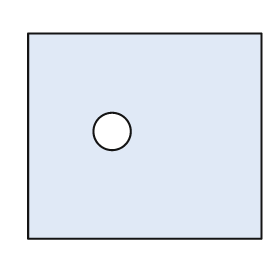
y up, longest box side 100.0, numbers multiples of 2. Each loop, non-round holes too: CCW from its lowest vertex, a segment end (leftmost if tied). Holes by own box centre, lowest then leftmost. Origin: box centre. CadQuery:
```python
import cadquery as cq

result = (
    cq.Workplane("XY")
    .moveTo(-50.0, -44.0)
    .lineTo(50.0, -44.0)
    .lineTo(50.0, 44.0)
    .lineTo(-50.0, 44.0)
    .close()
    .moveTo(-14.0, 2.0)
    .circle(8.0)
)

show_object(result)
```